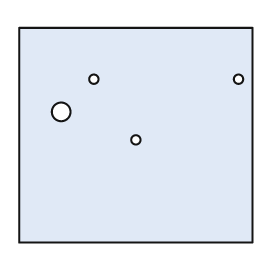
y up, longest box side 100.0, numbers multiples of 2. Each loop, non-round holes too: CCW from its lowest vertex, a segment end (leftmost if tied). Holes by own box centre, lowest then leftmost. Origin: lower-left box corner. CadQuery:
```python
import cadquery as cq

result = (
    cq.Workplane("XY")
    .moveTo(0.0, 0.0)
    .lineTo(100.0, 0.0)
    .lineTo(100.0, 92.0)
    .lineTo(0.0, 92.0)
    .close()
    .moveTo(50.0, 44.0)
    .circle(2.0)
    .moveTo(18.0, 56.0)
    .circle(4.0)
    .moveTo(32.0, 70.0)
    .circle(2.0)
    .moveTo(94.0, 70.0)
    .circle(2.0)
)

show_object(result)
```